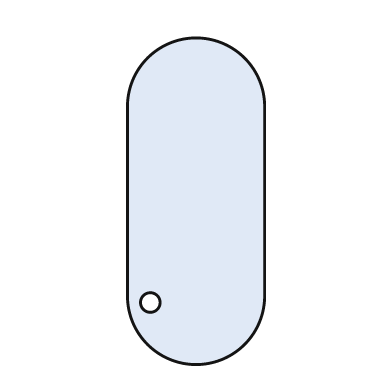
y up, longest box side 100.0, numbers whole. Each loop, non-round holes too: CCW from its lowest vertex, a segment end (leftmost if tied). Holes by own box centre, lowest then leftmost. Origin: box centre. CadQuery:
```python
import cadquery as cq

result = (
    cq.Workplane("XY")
    .moveTo(-21.0, -29.0)
    .threePointArc((0.0, -50.0), (21.0, -29.0))
    .lineTo(21.0, 29.0)
    .threePointArc((0.0, 50.0), (-21.0, 29.0))
    .close()
    .moveTo(-14.0, -31.0)
    .circle(3.0)
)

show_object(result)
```